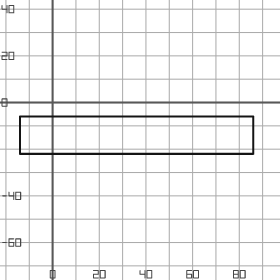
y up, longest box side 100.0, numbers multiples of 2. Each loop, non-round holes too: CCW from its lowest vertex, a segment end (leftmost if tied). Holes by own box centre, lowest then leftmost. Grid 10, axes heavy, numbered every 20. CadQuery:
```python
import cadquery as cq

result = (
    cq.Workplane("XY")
    .moveTo(-14.0, -22.0)
    .lineTo(86.0, -22.0)
    .lineTo(86.0, -6.0)
    .lineTo(-14.0, -6.0)
    .close()
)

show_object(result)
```